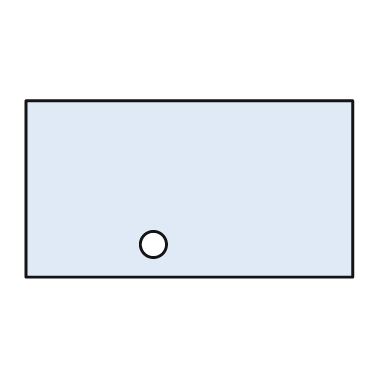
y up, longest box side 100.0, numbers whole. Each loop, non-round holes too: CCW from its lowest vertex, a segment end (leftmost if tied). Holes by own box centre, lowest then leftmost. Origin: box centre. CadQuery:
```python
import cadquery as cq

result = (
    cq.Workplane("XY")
    .moveTo(-50.0, -27.0)
    .lineTo(50.0, -27.0)
    .lineTo(50.0, 27.0)
    .lineTo(-50.0, 27.0)
    .close()
    .moveTo(-11.0, -17.0)
    .circle(4.0)
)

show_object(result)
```